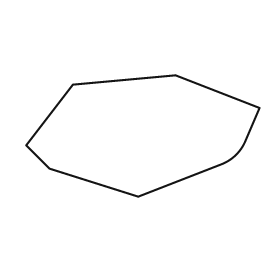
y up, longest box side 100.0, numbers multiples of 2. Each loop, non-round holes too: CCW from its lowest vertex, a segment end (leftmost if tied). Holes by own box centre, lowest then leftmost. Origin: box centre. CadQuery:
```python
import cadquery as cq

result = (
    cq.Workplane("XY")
    .moveTo(-2.0, -26.0)
    .lineTo(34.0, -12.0)
    .threePointArc((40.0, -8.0), (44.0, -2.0))
    .lineTo(50.0, 12.0)
    .lineTo(14.0, 26.0)
    .lineTo(-30.0, 22.0)
    .lineTo(-50.0, -4.0)
    .lineTo(-40.0, -14.0)
    .close()
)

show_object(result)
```